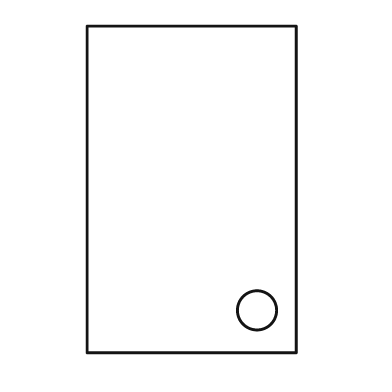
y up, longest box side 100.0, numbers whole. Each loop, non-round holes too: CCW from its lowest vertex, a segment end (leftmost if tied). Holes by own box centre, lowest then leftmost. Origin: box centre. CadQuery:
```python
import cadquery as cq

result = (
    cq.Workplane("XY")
    .moveTo(-32.0, -50.0)
    .lineTo(32.0, -50.0)
    .lineTo(32.0, 50.0)
    .lineTo(-32.0, 50.0)
    .close()
    .moveTo(20.0, -37.0)
    .circle(6.0)
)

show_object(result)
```